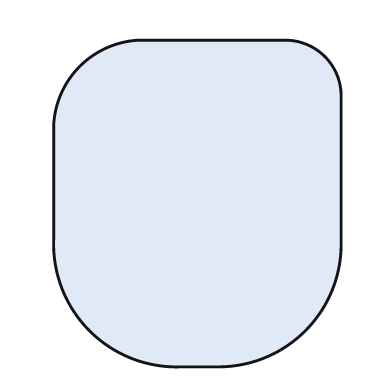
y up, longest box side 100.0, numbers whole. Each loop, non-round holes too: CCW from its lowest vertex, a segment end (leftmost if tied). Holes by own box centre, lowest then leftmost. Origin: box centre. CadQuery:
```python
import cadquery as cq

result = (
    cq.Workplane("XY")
    .moveTo(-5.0, -50.0)
    .lineTo(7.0, -50.0)
    .threePointArc((33.0, -39.0), (44.0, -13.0))
    .lineTo(44.0, 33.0)
    .threePointArc((39.0, 45.0), (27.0, 50.0))
    .lineTo(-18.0, 50.0)
    .threePointArc((-36.0, 42.0), (-44.0, 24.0))
    .lineTo(-44.0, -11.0)
    .threePointArc((-33.0, -39.0), (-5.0, -50.0))
    .close()
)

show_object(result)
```